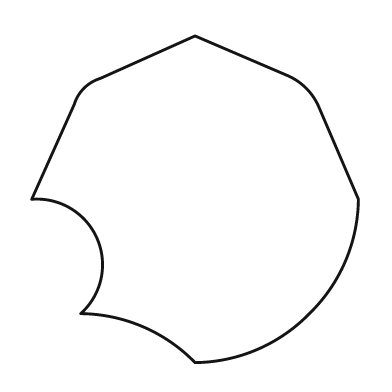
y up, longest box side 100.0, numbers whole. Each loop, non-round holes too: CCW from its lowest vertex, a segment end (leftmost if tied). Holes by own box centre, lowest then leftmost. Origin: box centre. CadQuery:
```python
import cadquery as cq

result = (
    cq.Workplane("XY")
    .moveTo(0.0, -50.0)
    .threePointArc((19.0, -46.0), (35.0, -35.0))
    .threePointArc((46.0, -19.0), (50.0, 0.0))
    .lineTo(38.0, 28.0)
    .threePointArc((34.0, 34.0), (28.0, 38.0))
    .lineTo(0.0, 50.0)
    .lineTo(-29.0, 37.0)
    .threePointArc((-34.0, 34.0), (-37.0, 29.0))
    .lineTo(-50.0, 0.0)
    .threePointArc((-30.0, -12.0), (-35.0, -35.0))
    .threePointArc((-16.0, -39.0), (0.0, -50.0))
    .close()
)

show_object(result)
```